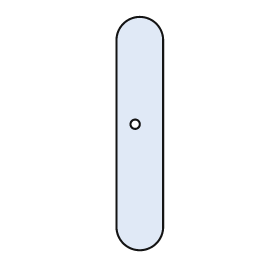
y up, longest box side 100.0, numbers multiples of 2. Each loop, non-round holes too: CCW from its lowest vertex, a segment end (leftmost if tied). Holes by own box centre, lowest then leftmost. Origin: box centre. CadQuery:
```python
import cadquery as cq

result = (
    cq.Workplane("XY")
    .moveTo(-10.0, -40.0)
    .threePointArc((0.0, -50.0), (10.0, -40.0))
    .lineTo(10.0, 40.0)
    .threePointArc((0.0, 50.0), (-10.0, 40.0))
    .close()
    .moveTo(-2.0, 4.0)
    .circle(2.0)
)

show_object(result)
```